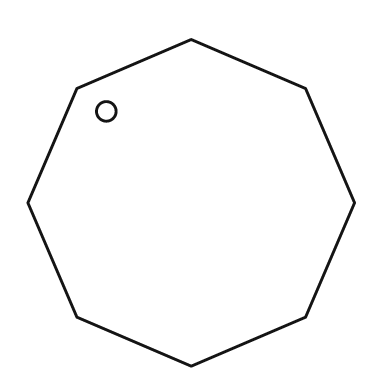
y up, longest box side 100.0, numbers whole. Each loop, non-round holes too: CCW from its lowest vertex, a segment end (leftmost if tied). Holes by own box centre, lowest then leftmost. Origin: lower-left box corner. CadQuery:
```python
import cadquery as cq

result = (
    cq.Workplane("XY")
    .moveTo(50.0, 0.0)
    .lineTo(85.0, 15.0)
    .lineTo(100.0, 50.0)
    .lineTo(85.0, 85.0)
    .lineTo(50.0, 100.0)
    .lineTo(15.0, 85.0)
    .lineTo(0.0, 50.0)
    .lineTo(15.0, 15.0)
    .close()
    .moveTo(24.0, 78.0)
    .circle(3.0)
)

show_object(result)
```